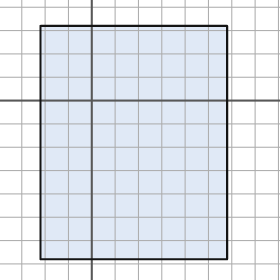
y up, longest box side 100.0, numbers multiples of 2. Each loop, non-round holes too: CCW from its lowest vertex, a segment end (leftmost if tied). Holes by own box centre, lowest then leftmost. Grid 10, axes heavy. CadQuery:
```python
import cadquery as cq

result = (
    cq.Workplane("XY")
    .moveTo(-22.0, -68.0)
    .lineTo(58.0, -68.0)
    .lineTo(58.0, 32.0)
    .lineTo(-22.0, 32.0)
    .close()
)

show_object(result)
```